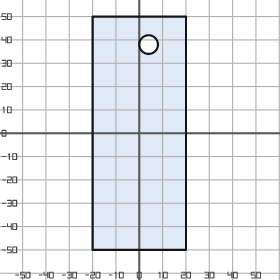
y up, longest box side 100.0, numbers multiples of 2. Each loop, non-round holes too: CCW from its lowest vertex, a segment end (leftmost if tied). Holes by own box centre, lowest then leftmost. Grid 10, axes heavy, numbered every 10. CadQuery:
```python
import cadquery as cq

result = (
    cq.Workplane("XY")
    .moveTo(-20.0, -50.0)
    .lineTo(20.0, -50.0)
    .lineTo(20.0, 50.0)
    .lineTo(-20.0, 50.0)
    .close()
    .moveTo(4.0, 38.0)
    .circle(4.0)
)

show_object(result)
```